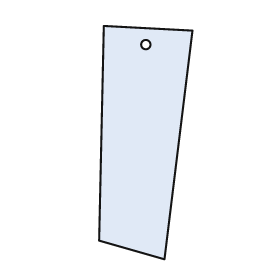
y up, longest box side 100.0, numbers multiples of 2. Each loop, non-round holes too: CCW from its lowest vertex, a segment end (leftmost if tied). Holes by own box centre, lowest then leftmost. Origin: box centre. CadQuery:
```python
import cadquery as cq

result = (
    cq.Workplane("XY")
    .moveTo(8.0, -50.0)
    .lineTo(20.0, 48.0)
    .lineTo(-18.0, 50.0)
    .lineTo(-20.0, -42.0)
    .close()
    .moveTo(0.0, 42.0)
    .circle(2.0)
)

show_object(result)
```